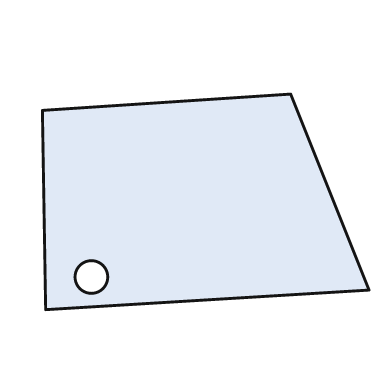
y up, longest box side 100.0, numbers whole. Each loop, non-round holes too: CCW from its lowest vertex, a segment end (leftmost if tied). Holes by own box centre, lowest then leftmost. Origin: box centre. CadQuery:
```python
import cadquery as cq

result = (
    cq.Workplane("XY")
    .moveTo(-49.0, -33.0)
    .lineTo(50.0, -27.0)
    .lineTo(26.0, 33.0)
    .lineTo(-50.0, 28.0)
    .close()
    .moveTo(-35.0, -23.0)
    .circle(5.0)
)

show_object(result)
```